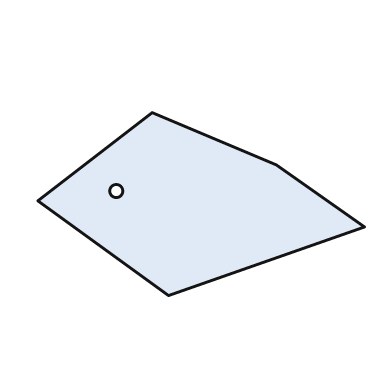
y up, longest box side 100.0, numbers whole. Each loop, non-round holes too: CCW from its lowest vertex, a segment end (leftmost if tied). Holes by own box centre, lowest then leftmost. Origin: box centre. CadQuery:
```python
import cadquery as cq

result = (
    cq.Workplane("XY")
    .moveTo(-10.0, -28.0)
    .lineTo(50.0, -7.0)
    .lineTo(23.0, 12.0)
    .lineTo(-15.0, 28.0)
    .lineTo(-50.0, 1.0)
    .close()
    .moveTo(-26.0, 4.0)
    .circle(2.0)
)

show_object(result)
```